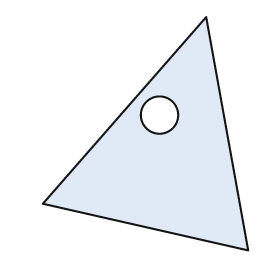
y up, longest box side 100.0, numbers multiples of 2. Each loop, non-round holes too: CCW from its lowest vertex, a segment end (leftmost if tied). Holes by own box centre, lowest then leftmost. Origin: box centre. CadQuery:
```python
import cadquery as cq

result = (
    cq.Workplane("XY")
    .moveTo(44.0, -50.0)
    .lineTo(26.0, 50.0)
    .lineTo(-44.0, -30.0)
    .close()
    .moveTo(6.0, 8.0)
    .circle(8.0)
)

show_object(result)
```